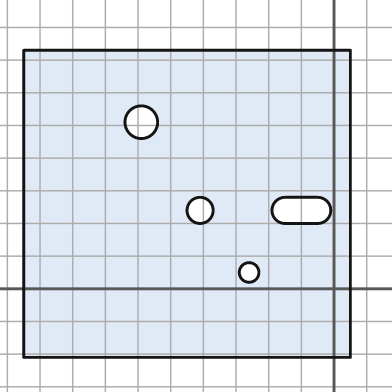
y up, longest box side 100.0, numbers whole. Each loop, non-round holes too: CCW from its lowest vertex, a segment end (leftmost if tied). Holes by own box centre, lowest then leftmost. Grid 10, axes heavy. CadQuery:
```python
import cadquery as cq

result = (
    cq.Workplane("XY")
    .moveTo(-95.0, -21.0)
    .lineTo(5.0, -21.0)
    .lineTo(5.0, 73.0)
    .lineTo(-95.0, 73.0)
    .close()
    .moveTo(-26.0, 5.0)
    .circle(3.0)
    .moveTo(-41.0, 24.0)
    .circle(4.0)
    .moveTo(-15.0, 20.0)
    .lineTo(-5.0, 20.0)
    .threePointArc((-1.0, 24.0), (-5.0, 28.0))
    .lineTo(-15.0, 28.0)
    .threePointArc((-19.0, 24.0), (-15.0, 20.0))
    .close()
    .moveTo(-59.0, 51.0)
    .circle(5.0)
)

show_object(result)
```